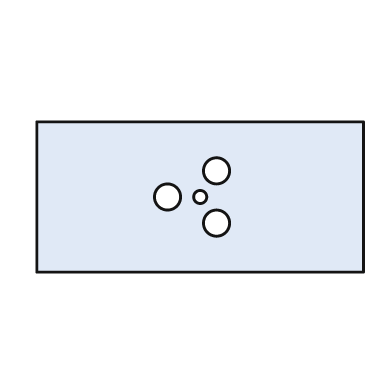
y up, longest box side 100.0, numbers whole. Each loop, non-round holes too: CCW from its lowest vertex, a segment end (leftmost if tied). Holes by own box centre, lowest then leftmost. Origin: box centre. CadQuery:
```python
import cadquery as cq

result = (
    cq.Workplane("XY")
    .moveTo(-50.0, -23.0)
    .lineTo(50.0, -23.0)
    .lineTo(50.0, 23.0)
    .lineTo(-50.0, 23.0)
    .close()
    .moveTo(5.0, -8.0)
    .circle(4.0)
    .moveTo(-10.0, 0.0)
    .circle(4.0)
    .moveTo(0.0, 0.0)
    .circle(2.0)
    .moveTo(5.0, 8.0)
    .circle(4.0)
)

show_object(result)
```